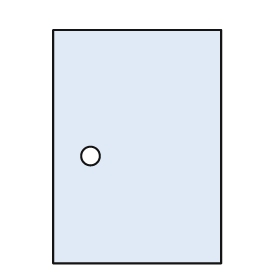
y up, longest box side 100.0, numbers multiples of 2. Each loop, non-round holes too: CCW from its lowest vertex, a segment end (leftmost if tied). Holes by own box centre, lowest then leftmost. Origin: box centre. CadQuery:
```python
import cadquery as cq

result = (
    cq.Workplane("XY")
    .moveTo(-36.0, -50.0)
    .lineTo(36.0, -50.0)
    .lineTo(36.0, 50.0)
    .lineTo(-36.0, 50.0)
    .close()
    .moveTo(-20.0, -4.0)
    .circle(4.0)
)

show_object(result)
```